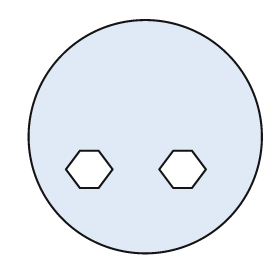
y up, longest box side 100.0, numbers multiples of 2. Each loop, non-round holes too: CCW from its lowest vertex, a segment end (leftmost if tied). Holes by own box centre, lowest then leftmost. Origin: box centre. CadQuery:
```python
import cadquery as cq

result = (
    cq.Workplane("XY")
    .moveTo(0.0, 0.0)
    .circle(50.0)
    .moveTo(-28.0, -22.0)
    .lineTo(-20.0, -22.0)
    .lineTo(-14.0, -14.0)
    .lineTo(-20.0, -6.0)
    .lineTo(-28.0, -6.0)
    .lineTo(-34.0, -14.0)
    .close()
    .moveTo(12.0, -22.0)
    .lineTo(20.0, -22.0)
    .lineTo(26.0, -14.0)
    .lineTo(20.0, -6.0)
    .lineTo(12.0, -6.0)
    .lineTo(6.0, -14.0)
    .close()
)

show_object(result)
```